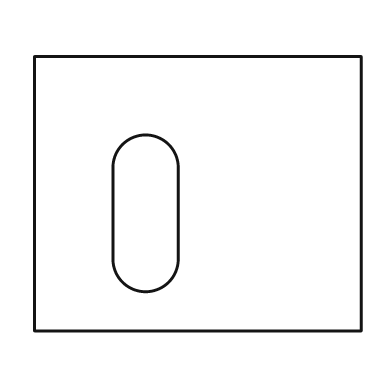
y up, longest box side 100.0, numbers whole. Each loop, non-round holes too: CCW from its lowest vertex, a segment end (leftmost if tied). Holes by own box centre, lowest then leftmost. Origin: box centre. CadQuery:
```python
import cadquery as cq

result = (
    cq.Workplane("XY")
    .moveTo(-50.0, -42.0)
    .lineTo(50.0, -42.0)
    .lineTo(50.0, 42.0)
    .lineTo(-50.0, 42.0)
    .close()
    .moveTo(-26.0, -20.0)
    .threePointArc((-16.0, -30.0), (-6.0, -20.0))
    .lineTo(-6.0, 8.0)
    .threePointArc((-16.0, 18.0), (-26.0, 8.0))
    .close()
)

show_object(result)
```